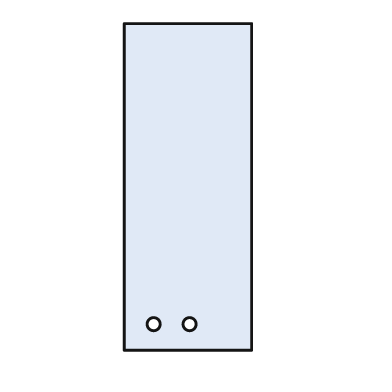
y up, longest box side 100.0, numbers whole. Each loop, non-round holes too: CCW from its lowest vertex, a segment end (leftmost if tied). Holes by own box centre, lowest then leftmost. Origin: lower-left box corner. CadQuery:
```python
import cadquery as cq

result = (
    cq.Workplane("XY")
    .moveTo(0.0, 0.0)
    .lineTo(39.0, 0.0)
    .lineTo(39.0, 100.0)
    .lineTo(0.0, 100.0)
    .close()
    .moveTo(9.0, 8.0)
    .circle(2.0)
    .moveTo(20.0, 8.0)
    .circle(2.0)
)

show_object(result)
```